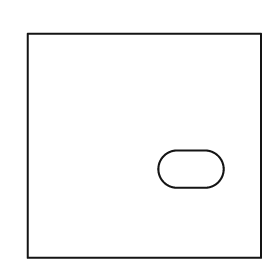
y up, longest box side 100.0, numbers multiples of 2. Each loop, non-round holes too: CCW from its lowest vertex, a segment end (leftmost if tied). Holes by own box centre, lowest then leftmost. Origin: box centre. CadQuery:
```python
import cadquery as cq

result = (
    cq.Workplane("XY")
    .moveTo(-50.0, -48.0)
    .lineTo(50.0, -48.0)
    .lineTo(50.0, 48.0)
    .lineTo(-50.0, 48.0)
    .close()
    .moveTo(14.0, -18.0)
    .lineTo(26.0, -18.0)
    .threePointArc((34.0, -10.0), (26.0, -2.0))
    .lineTo(14.0, -2.0)
    .threePointArc((6.0, -10.0), (14.0, -18.0))
    .close()
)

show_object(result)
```